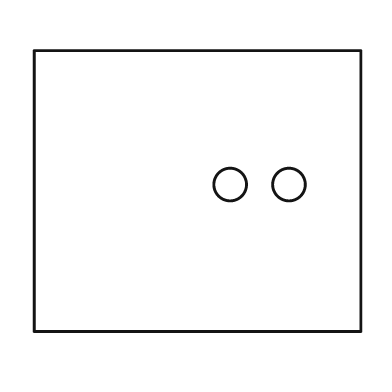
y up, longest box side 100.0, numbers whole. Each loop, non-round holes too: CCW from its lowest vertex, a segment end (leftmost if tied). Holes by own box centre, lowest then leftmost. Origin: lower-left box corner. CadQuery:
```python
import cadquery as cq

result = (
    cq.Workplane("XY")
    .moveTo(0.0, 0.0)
    .lineTo(100.0, 0.0)
    .lineTo(100.0, 86.0)
    .lineTo(0.0, 86.0)
    .close()
    .moveTo(60.0, 45.0)
    .circle(5.0)
    .moveTo(78.0, 45.0)
    .circle(5.0)
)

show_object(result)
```